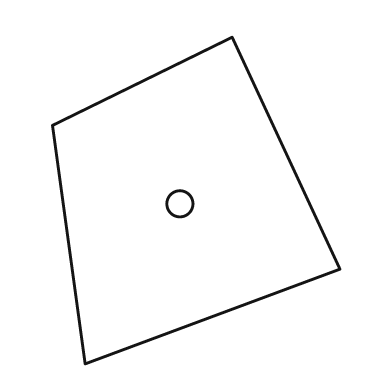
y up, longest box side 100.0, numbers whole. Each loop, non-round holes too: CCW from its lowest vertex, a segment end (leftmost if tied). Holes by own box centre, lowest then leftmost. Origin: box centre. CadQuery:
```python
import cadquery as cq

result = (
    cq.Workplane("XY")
    .moveTo(-34.0, -50.0)
    .lineTo(44.0, -21.0)
    .lineTo(11.0, 50.0)
    .lineTo(-44.0, 23.0)
    .close()
    .moveTo(-5.0, -1.0)
    .circle(4.0)
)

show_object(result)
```